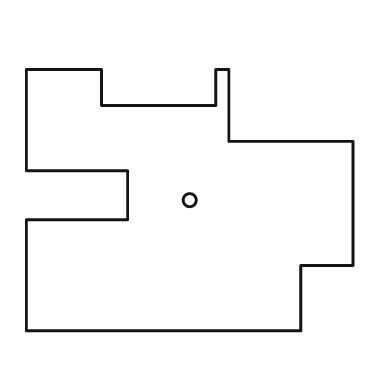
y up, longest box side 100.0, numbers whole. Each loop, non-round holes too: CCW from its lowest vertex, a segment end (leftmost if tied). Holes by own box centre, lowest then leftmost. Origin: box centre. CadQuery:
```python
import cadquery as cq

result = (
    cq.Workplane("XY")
    .moveTo(-50.0, -40.0)
    .lineTo(34.0, -40.0)
    .lineTo(34.0, -20.0)
    .lineTo(50.0, -20.0)
    .lineTo(50.0, 18.0)
    .lineTo(12.0, 18.0)
    .lineTo(12.0, 40.0)
    .lineTo(8.0, 40.0)
    .lineTo(8.0, 29.0)
    .lineTo(-27.0, 29.0)
    .lineTo(-27.0, 40.0)
    .lineTo(-50.0, 40.0)
    .lineTo(-50.0, 9.0)
    .lineTo(-19.0, 9.0)
    .lineTo(-19.0, -6.0)
    .lineTo(-50.0, -6.0)
    .close()
    .moveTo(0.0, 0.0)
    .circle(2.0)
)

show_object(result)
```